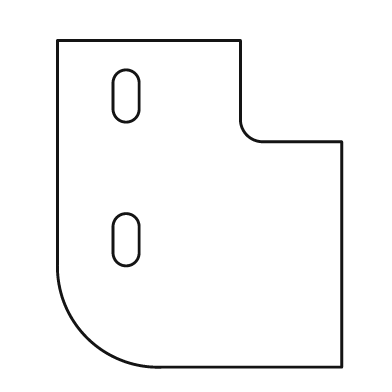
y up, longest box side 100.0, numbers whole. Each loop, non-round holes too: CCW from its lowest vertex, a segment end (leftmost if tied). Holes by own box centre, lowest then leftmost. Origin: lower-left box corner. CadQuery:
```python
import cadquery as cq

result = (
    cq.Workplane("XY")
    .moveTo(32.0, 0.0)
    .lineTo(87.0, 0.0)
    .lineTo(87.0, 69.0)
    .lineTo(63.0, 69.0)
    .threePointArc((58.0, 71.0), (56.0, 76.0))
    .lineTo(56.0, 100.0)
    .lineTo(0.0, 100.0)
    .lineTo(0.0, 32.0)
    .threePointArc((9.0, 9.0), (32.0, 0.0))
    .close()
    .moveTo(17.0, 35.0)
    .threePointArc((21.0, 31.0), (25.0, 35.0))
    .lineTo(25.0, 43.0)
    .threePointArc((21.0, 47.0), (17.0, 43.0))
    .close()
    .moveTo(17.0, 79.0)
    .threePointArc((21.0, 75.0), (25.0, 79.0))
    .lineTo(25.0, 87.0)
    .threePointArc((21.0, 91.0), (17.0, 87.0))
    .close()
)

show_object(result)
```